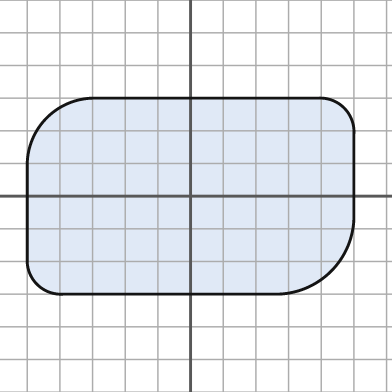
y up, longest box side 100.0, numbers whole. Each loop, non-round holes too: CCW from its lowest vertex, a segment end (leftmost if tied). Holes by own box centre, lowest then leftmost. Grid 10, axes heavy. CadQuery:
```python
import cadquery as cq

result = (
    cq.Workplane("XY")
    .moveTo(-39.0, -30.0)
    .lineTo(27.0, -30.0)
    .threePointArc((43.0, -23.0), (50.0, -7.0))
    .lineTo(50.0, 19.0)
    .threePointArc((47.0, 27.0), (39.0, 30.0))
    .lineTo(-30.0, 30.0)
    .threePointArc((-44.0, 24.0), (-50.0, 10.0))
    .lineTo(-50.0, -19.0)
    .threePointArc((-47.0, -27.0), (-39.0, -30.0))
    .close()
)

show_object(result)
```